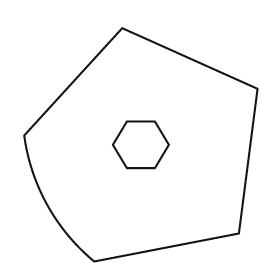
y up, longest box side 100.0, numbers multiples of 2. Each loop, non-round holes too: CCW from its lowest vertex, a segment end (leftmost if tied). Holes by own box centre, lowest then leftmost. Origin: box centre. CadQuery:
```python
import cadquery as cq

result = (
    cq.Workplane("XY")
    .moveTo(-20.0, -50.0)
    .lineTo(42.0, -38.0)
    .lineTo(50.0, 24.0)
    .lineTo(-8.0, 50.0)
    .lineTo(-50.0, 4.0)
    .threePointArc((-40.0, -26.0), (-20.0, -50.0))
    .close()
    .moveTo(-6.0, -10.0)
    .lineTo(6.0, -10.0)
    .lineTo(12.0, 0.0)
    .lineTo(6.0, 10.0)
    .lineTo(-6.0, 10.0)
    .lineTo(-12.0, 0.0)
    .close()
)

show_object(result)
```